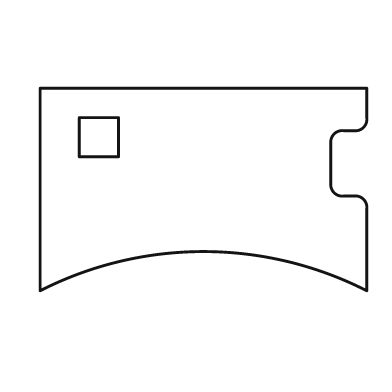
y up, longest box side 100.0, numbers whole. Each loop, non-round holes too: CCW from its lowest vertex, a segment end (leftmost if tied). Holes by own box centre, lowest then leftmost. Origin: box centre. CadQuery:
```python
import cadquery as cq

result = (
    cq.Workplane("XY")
    .moveTo(-50.0, -31.0)
    .threePointArc((0.0, -19.0), (50.0, -31.0))
    .lineTo(50.0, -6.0)
    .threePointArc((49.0, -3.0), (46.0, -2.0))
    .lineTo(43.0, -2.0)
    .threePointArc((40.0, -1.0), (39.0, 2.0))
    .lineTo(39.0, 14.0)
    .threePointArc((40.0, 17.0), (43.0, 18.0))
    .lineTo(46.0, 18.0)
    .threePointArc((49.0, 19.0), (50.0, 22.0))
    .lineTo(50.0, 31.0)
    .lineTo(-50.0, 31.0)
    .close()
    .moveTo(-38.0, 10.0)
    .lineTo(-26.0, 10.0)
    .lineTo(-26.0, 22.0)
    .lineTo(-38.0, 22.0)
    .close()
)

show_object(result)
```